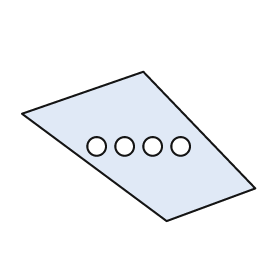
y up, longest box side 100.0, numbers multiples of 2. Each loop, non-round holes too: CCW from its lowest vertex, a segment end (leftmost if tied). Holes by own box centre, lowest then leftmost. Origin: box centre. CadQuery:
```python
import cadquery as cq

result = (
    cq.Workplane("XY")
    .moveTo(12.0, -32.0)
    .lineTo(50.0, -18.0)
    .lineTo(2.0, 32.0)
    .lineTo(-50.0, 14.0)
    .close()
    .moveTo(-18.0, 0.0)
    .circle(4.0)
    .moveTo(-6.0, 0.0)
    .circle(4.0)
    .moveTo(6.0, 0.0)
    .circle(4.0)
    .moveTo(18.0, 0.0)
    .circle(4.0)
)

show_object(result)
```